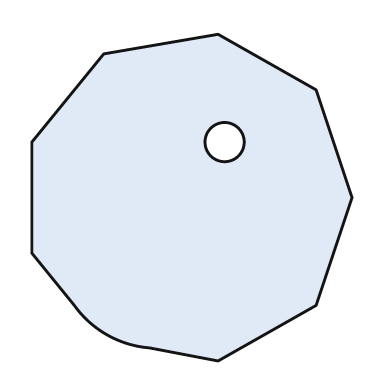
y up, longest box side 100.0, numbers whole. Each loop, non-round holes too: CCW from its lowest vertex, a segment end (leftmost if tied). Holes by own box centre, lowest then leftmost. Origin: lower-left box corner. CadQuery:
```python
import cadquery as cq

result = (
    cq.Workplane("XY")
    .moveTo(57.0, 0.0)
    .lineTo(87.0, 17.0)
    .lineTo(98.0, 50.0)
    .lineTo(87.0, 83.0)
    .lineTo(57.0, 100.0)
    .lineTo(22.0, 94.0)
    .lineTo(0.0, 67.0)
    .lineTo(0.0, 33.0)
    .lineTo(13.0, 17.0)
    .threePointArc((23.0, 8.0), (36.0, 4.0))
    .close()
    .moveTo(59.0, 67.0)
    .circle(6.0)
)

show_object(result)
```